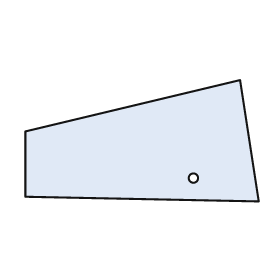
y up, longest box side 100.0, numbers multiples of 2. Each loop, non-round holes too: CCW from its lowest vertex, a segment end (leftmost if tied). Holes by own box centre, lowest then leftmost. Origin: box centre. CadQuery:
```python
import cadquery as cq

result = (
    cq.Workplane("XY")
    .moveTo(50.0, -26.0)
    .lineTo(42.0, 26.0)
    .lineTo(-50.0, 4.0)
    .lineTo(-50.0, -24.0)
    .close()
    .moveTo(22.0, -16.0)
    .circle(2.0)
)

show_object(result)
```